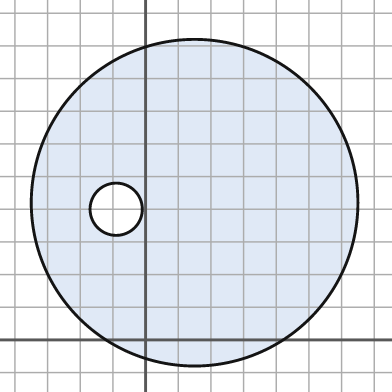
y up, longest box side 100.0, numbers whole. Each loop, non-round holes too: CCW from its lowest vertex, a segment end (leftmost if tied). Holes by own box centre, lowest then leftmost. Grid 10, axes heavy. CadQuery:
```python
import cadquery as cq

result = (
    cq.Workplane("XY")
    .moveTo(15.0, 42.0)
    .circle(50.0)
    .moveTo(-9.0, 40.0)
    .circle(8.0)
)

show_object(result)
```